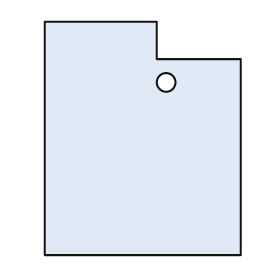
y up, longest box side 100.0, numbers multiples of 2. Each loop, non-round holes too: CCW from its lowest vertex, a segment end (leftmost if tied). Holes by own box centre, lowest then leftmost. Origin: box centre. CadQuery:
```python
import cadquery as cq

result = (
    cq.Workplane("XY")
    .moveTo(-42.0, -50.0)
    .lineTo(42.0, -50.0)
    .lineTo(42.0, 34.0)
    .lineTo(6.0, 34.0)
    .lineTo(6.0, 50.0)
    .lineTo(-42.0, 50.0)
    .close()
    .moveTo(10.0, 24.0)
    .circle(4.0)
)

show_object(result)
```